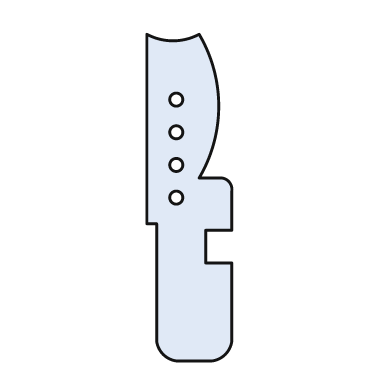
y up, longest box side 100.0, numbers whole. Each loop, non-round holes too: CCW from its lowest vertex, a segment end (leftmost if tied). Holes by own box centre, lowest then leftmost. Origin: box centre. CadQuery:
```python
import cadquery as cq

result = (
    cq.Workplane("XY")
    .moveTo(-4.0, -50.0)
    .lineTo(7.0, -50.0)
    .threePointArc((11.0, -48.0), (13.0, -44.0))
    .lineTo(13.0, -20.0)
    .lineTo(5.0, -20.0)
    .lineTo(5.0, -10.0)
    .lineTo(13.0, -10.0)
    .lineTo(13.0, 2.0)
    .threePointArc((12.0, 5.0), (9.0, 6.0))
    .lineTo(3.0, 6.0)
    .threePointArc((9.0, 28.0), (3.0, 50.0))
    .threePointArc((-5.0, 48.0), (-13.0, 50.0))
    .lineTo(-13.0, -8.0)
    .lineTo(-10.0, -8.0)
    .lineTo(-10.0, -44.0)
    .threePointArc((-8.0, -48.0), (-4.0, -50.0))
    .close()
    .moveTo(-4.0, 0.0)
    .circle(2.0)
    .moveTo(-4.0, 10.0)
    .circle(2.0)
    .moveTo(-4.0, 20.0)
    .circle(2.0)
    .moveTo(-4.0, 30.0)
    .circle(2.0)
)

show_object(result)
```